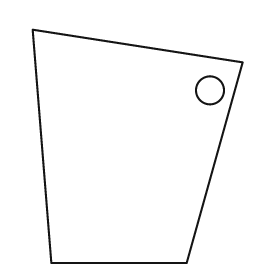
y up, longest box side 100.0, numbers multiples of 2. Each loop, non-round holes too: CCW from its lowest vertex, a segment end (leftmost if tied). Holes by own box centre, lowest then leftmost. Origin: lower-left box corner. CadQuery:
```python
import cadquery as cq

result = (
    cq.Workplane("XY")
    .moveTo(8.0, 0.0)
    .lineTo(66.0, 0.0)
    .lineTo(90.0, 86.0)
    .lineTo(0.0, 100.0)
    .close()
    .moveTo(76.0, 74.0)
    .circle(6.0)
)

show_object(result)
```